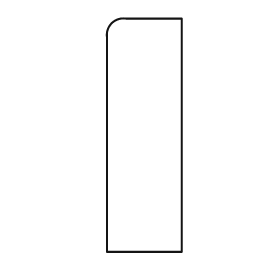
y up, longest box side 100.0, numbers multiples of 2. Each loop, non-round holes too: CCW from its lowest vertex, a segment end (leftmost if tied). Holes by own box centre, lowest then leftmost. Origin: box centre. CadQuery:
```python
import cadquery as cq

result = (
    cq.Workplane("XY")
    .moveTo(-16.0, -50.0)
    .lineTo(16.0, -50.0)
    .lineTo(16.0, 50.0)
    .lineTo(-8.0, 50.0)
    .threePointArc((-14.0, 48.0), (-16.0, 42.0))
    .close()
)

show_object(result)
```